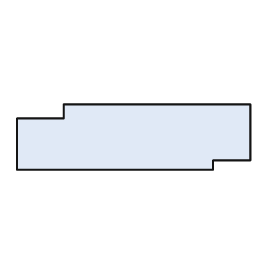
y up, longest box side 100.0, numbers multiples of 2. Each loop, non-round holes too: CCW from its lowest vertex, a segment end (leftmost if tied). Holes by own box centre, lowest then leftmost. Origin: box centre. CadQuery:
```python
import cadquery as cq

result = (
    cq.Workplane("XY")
    .moveTo(-50.0, -14.0)
    .lineTo(34.0, -14.0)
    .lineTo(34.0, -10.0)
    .lineTo(50.0, -10.0)
    .lineTo(50.0, 14.0)
    .lineTo(-30.0, 14.0)
    .lineTo(-30.0, 8.0)
    .lineTo(-50.0, 8.0)
    .close()
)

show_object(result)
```